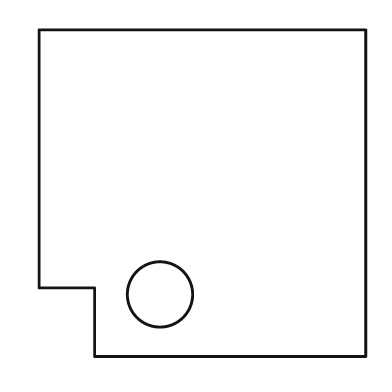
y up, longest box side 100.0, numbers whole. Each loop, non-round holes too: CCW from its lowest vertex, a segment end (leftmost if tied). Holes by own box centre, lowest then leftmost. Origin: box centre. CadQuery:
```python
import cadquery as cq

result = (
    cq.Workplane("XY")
    .moveTo(-33.0, -50.0)
    .lineTo(50.0, -50.0)
    .lineTo(50.0, 50.0)
    .lineTo(-50.0, 50.0)
    .lineTo(-50.0, -29.0)
    .lineTo(-33.0, -29.0)
    .close()
    .moveTo(-13.0, -31.0)
    .circle(10.0)
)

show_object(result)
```